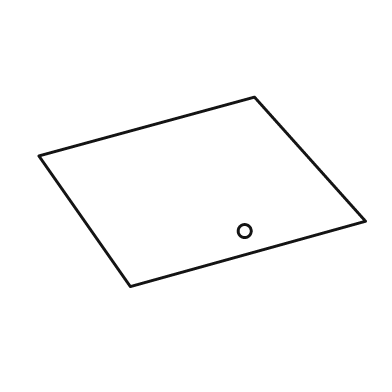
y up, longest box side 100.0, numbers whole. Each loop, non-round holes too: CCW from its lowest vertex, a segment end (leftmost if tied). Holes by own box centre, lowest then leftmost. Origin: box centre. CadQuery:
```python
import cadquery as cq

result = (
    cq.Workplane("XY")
    .moveTo(-22.0, -29.0)
    .lineTo(50.0, -9.0)
    .lineTo(16.0, 29.0)
    .lineTo(-50.0, 11.0)
    .close()
    .moveTo(13.0, -12.0)
    .circle(2.0)
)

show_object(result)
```